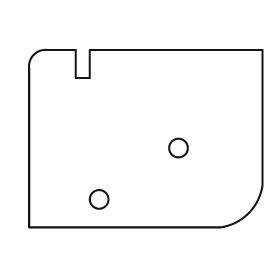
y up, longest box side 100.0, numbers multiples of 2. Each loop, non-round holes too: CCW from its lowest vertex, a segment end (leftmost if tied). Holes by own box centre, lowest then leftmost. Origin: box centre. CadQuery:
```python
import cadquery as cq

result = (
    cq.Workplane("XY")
    .moveTo(-50.0, -38.0)
    .lineTo(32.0, -38.0)
    .threePointArc((44.0, -32.0), (50.0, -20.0))
    .lineTo(50.0, 38.0)
    .lineTo(-24.0, 38.0)
    .lineTo(-24.0, 26.0)
    .lineTo(-30.0, 26.0)
    .lineTo(-30.0, 38.0)
    .lineTo(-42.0, 38.0)
    .threePointArc((-48.0, 36.0), (-50.0, 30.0))
    .close()
    .moveTo(-20.0, -26.0)
    .circle(4.0)
    .moveTo(14.0, -4.0)
    .circle(4.0)
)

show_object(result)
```